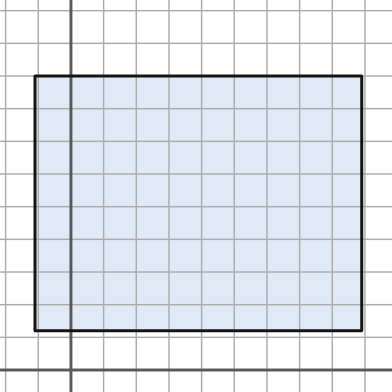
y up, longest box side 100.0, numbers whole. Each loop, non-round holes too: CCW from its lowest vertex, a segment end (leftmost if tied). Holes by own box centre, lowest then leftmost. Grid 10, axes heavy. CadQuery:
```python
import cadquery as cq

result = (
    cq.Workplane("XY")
    .moveTo(-11.0, 12.0)
    .lineTo(89.0, 12.0)
    .lineTo(89.0, 90.0)
    .lineTo(-11.0, 90.0)
    .close()
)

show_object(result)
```